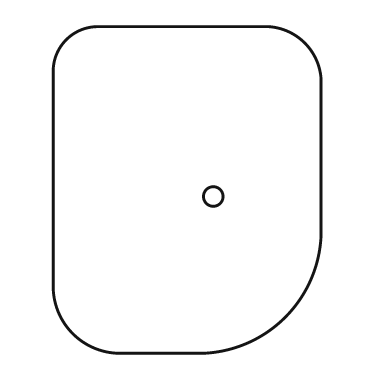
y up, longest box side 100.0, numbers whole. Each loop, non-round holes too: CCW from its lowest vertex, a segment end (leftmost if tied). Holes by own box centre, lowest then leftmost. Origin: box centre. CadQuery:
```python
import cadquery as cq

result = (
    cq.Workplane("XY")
    .moveTo(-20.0, -50.0)
    .lineTo(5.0, -50.0)
    .threePointArc((30.0, -39.0), (41.0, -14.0))
    .lineTo(41.0, 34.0)
    .threePointArc((36.0, 45.0), (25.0, 50.0))
    .lineTo(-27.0, 50.0)
    .threePointArc((-37.0, 46.0), (-41.0, 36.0))
    .lineTo(-41.0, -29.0)
    .threePointArc((-35.0, -44.0), (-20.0, -50.0))
    .close()
    .moveTo(8.0, -2.0)
    .circle(3.0)
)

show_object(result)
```